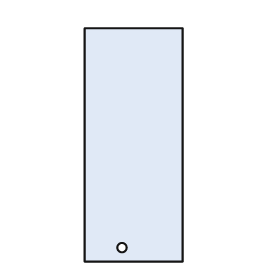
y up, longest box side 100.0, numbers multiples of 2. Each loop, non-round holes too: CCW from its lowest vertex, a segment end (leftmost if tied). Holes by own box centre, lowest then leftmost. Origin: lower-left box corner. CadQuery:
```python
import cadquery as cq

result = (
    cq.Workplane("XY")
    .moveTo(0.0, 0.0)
    .lineTo(42.0, 0.0)
    .lineTo(42.0, 100.0)
    .lineTo(0.0, 100.0)
    .close()
    .moveTo(16.0, 6.0)
    .circle(2.0)
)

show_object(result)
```